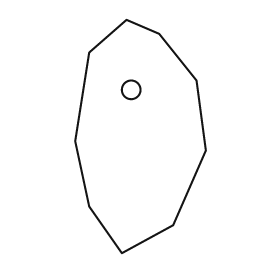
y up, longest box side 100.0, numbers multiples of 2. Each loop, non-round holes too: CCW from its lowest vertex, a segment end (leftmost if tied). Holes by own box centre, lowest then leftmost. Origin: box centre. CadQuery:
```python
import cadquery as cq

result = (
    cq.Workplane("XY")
    .moveTo(-8.0, -50.0)
    .lineTo(14.0, -38.0)
    .lineTo(28.0, -6.0)
    .lineTo(24.0, 24.0)
    .lineTo(8.0, 44.0)
    .lineTo(-6.0, 50.0)
    .lineTo(-22.0, 36.0)
    .lineTo(-28.0, -2.0)
    .lineTo(-22.0, -30.0)
    .close()
    .moveTo(-4.0, 20.0)
    .circle(4.0)
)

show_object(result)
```